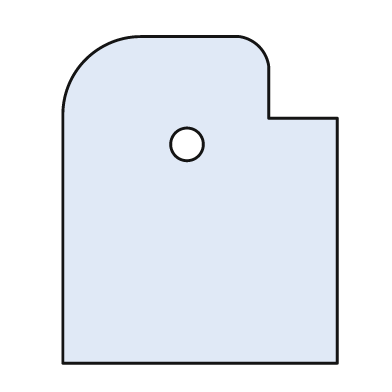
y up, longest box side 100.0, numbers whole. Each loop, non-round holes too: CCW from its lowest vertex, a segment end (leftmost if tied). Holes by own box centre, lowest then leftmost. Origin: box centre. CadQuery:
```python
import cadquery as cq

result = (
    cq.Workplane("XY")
    .moveTo(-42.0, -50.0)
    .lineTo(42.0, -50.0)
    .lineTo(42.0, 25.0)
    .lineTo(21.0, 25.0)
    .lineTo(21.0, 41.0)
    .threePointArc((18.0, 47.0), (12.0, 50.0))
    .lineTo(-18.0, 50.0)
    .threePointArc((-35.0, 43.0), (-42.0, 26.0))
    .close()
    .moveTo(-4.0, 17.0)
    .circle(5.0)
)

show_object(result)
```